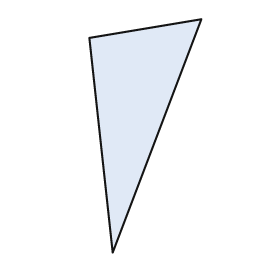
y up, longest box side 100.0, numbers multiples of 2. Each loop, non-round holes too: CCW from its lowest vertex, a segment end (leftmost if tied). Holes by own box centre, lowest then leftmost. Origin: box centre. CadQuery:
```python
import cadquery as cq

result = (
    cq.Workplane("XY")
    .moveTo(-14.0, -50.0)
    .lineTo(24.0, 50.0)
    .lineTo(-24.0, 42.0)
    .close()
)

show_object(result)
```